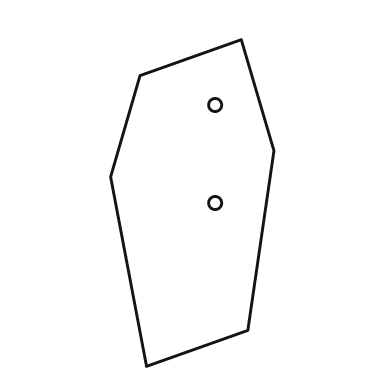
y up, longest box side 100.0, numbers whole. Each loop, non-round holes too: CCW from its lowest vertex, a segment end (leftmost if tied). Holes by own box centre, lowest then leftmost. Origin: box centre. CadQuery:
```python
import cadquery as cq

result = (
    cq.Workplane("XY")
    .moveTo(-14.0, -50.0)
    .lineTo(17.0, -39.0)
    .lineTo(25.0, 16.0)
    .lineTo(15.0, 50.0)
    .lineTo(-16.0, 39.0)
    .lineTo(-25.0, 8.0)
    .close()
    .moveTo(7.0, 0.0)
    .circle(2.0)
    .moveTo(7.0, 30.0)
    .circle(2.0)
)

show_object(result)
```